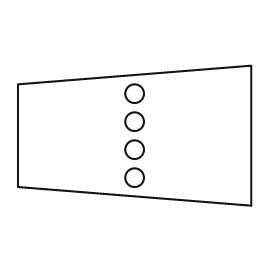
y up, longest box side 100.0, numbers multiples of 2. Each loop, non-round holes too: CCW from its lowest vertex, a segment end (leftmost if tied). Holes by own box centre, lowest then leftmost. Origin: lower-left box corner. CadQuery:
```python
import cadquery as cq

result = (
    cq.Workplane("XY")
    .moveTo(100.0, 0.0)
    .lineTo(100.0, 60.0)
    .lineTo(0.0, 52.0)
    .lineTo(0.0, 8.0)
    .close()
    .moveTo(50.0, 12.0)
    .circle(4.0)
    .moveTo(50.0, 24.0)
    .circle(4.0)
    .moveTo(50.0, 36.0)
    .circle(4.0)
    .moveTo(50.0, 48.0)
    .circle(4.0)
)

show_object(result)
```